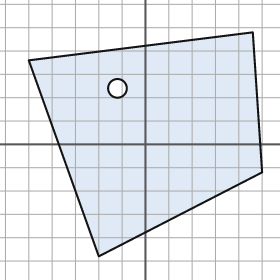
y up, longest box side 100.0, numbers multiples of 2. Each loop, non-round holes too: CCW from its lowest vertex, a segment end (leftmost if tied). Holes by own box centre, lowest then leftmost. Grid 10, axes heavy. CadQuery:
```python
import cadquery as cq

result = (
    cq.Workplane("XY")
    .moveTo(-20.0, -48.0)
    .lineTo(50.0, -12.0)
    .lineTo(46.0, 48.0)
    .lineTo(-50.0, 36.0)
    .close()
    .moveTo(-12.0, 24.0)
    .circle(4.0)
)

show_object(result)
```